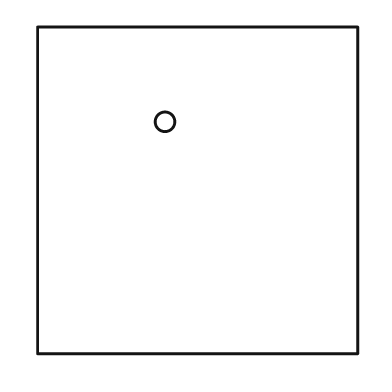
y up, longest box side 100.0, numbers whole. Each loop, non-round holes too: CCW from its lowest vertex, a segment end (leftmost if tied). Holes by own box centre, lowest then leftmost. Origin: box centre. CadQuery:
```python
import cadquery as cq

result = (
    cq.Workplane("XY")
    .moveTo(-49.0, -50.0)
    .lineTo(49.0, -50.0)
    .lineTo(49.0, 50.0)
    .lineTo(-49.0, 50.0)
    .close()
    .moveTo(-10.0, 21.0)
    .circle(3.0)
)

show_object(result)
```